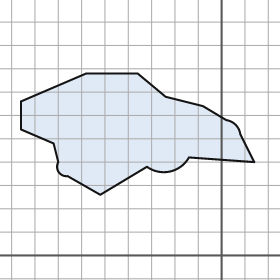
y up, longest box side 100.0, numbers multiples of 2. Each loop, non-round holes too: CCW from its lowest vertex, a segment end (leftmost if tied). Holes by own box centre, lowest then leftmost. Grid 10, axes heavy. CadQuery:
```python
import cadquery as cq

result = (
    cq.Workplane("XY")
    .moveTo(-52.0, 26.0)
    .lineTo(-32.0, 38.0)
    .threePointArc((-22.0, 36.0), (-14.0, 42.0))
    .lineTo(14.0, 40.0)
    .lineTo(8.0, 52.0)
    .threePointArc((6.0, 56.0), (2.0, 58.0))
    .lineTo(-8.0, 64.0)
    .lineTo(-24.0, 68.0)
    .lineTo(-36.0, 78.0)
    .lineTo(-58.0, 78.0)
    .lineTo(-86.0, 66.0)
    .lineTo(-86.0, 54.0)
    .lineTo(-72.0, 48.0)
    .lineTo(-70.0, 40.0)
    .threePointArc((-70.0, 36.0), (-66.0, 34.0))
    .close()
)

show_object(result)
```